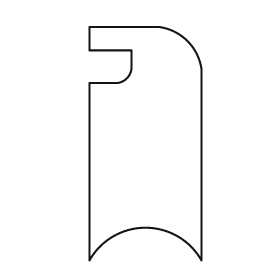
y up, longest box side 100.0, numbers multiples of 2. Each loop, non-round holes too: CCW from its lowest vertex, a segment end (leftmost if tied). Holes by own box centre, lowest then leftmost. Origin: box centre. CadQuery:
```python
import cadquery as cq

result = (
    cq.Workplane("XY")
    .moveTo(-24.0, -50.0)
    .threePointArc((0.0, -36.0), (24.0, -50.0))
    .lineTo(24.0, 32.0)
    .threePointArc((18.0, 44.0), (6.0, 50.0))
    .lineTo(-24.0, 50.0)
    .lineTo(-24.0, 40.0)
    .lineTo(-6.0, 40.0)
    .lineTo(-6.0, 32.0)
    .threePointArc((-8.0, 28.0), (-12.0, 26.0))
    .lineTo(-24.0, 26.0)
    .close()
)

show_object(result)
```